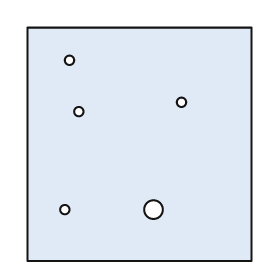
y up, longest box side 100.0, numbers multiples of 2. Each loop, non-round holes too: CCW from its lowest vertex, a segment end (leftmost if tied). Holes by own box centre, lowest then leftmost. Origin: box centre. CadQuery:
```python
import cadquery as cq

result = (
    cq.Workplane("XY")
    .moveTo(-48.0, -50.0)
    .lineTo(48.0, -50.0)
    .lineTo(48.0, 50.0)
    .lineTo(-48.0, 50.0)
    .close()
    .moveTo(-32.0, -28.0)
    .circle(2.0)
    .moveTo(6.0, -28.0)
    .circle(4.0)
    .moveTo(-26.0, 14.0)
    .circle(2.0)
    .moveTo(18.0, 18.0)
    .circle(2.0)
    .moveTo(-30.0, 36.0)
    .circle(2.0)
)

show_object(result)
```